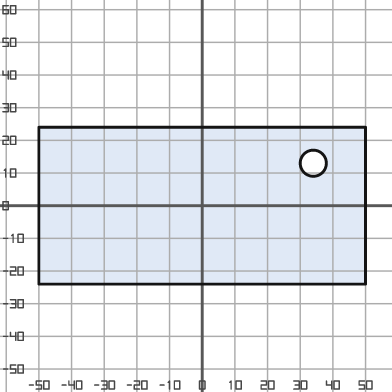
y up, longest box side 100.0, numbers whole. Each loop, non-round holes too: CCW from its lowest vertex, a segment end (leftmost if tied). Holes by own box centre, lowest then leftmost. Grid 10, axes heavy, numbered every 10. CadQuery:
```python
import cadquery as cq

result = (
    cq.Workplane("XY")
    .moveTo(-50.0, -24.0)
    .lineTo(50.0, -24.0)
    .lineTo(50.0, 24.0)
    .lineTo(-50.0, 24.0)
    .close()
    .moveTo(34.0, 13.0)
    .circle(4.0)
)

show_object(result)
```